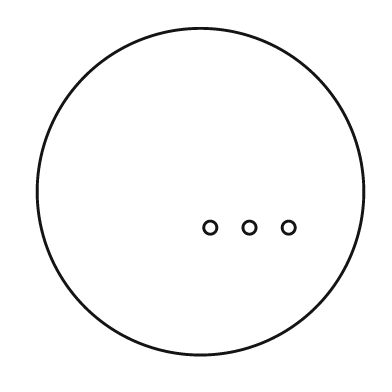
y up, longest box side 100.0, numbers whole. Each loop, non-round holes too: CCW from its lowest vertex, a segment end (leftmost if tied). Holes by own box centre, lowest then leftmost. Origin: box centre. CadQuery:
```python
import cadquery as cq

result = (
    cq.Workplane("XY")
    .moveTo(0.0, 0.0)
    .circle(50.0)
    .moveTo(3.0, -11.0)
    .circle(2.0)
    .moveTo(15.0, -11.0)
    .circle(2.0)
    .moveTo(27.0, -11.0)
    .circle(2.0)
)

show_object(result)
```